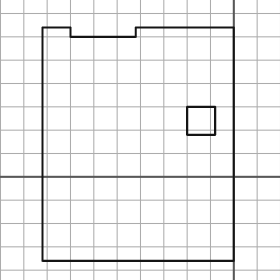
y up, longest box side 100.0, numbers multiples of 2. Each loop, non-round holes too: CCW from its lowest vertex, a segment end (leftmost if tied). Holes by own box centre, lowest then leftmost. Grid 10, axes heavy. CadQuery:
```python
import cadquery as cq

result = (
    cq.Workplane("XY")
    .moveTo(-82.0, -36.0)
    .lineTo(0.0, -36.0)
    .lineTo(0.0, 64.0)
    .lineTo(-42.0, 64.0)
    .lineTo(-42.0, 60.0)
    .lineTo(-70.0, 60.0)
    .lineTo(-70.0, 64.0)
    .lineTo(-82.0, 64.0)
    .close()
    .moveTo(-20.0, 18.0)
    .lineTo(-8.0, 18.0)
    .lineTo(-8.0, 30.0)
    .lineTo(-20.0, 30.0)
    .close()
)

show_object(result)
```